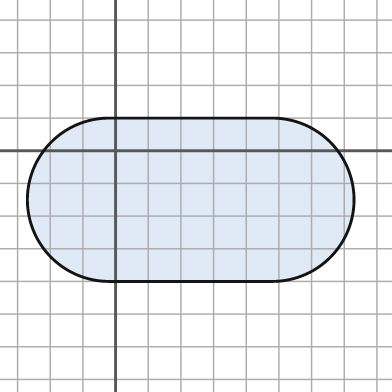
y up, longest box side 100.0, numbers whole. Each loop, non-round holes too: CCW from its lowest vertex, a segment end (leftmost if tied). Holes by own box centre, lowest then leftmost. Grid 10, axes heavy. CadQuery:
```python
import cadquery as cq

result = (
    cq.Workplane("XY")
    .moveTo(-2.0, -40.0)
    .lineTo(48.0, -40.0)
    .threePointArc((73.0, -15.0), (48.0, 10.0))
    .lineTo(-2.0, 10.0)
    .threePointArc((-27.0, -15.0), (-2.0, -40.0))
    .close()
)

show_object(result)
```